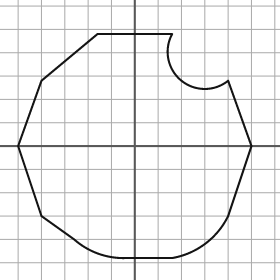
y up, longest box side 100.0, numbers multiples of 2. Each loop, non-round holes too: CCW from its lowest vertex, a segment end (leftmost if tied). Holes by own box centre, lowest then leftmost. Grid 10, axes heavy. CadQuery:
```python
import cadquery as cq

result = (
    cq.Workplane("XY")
    .moveTo(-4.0, -48.0)
    .lineTo(16.0, -48.0)
    .threePointArc((30.0, -42.0), (40.0, -30.0))
    .lineTo(50.0, 0.0)
    .lineTo(40.0, 28.0)
    .threePointArc((20.0, 28.0), (16.0, 48.0))
    .lineTo(-16.0, 48.0)
    .lineTo(-40.0, 28.0)
    .lineTo(-50.0, 0.0)
    .lineTo(-40.0, -30.0)
    .lineTo(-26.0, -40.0)
    .threePointArc((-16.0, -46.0), (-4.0, -48.0))
    .close()
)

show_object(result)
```